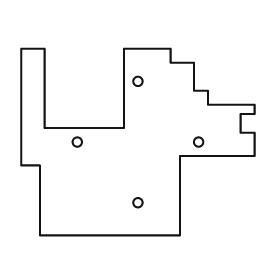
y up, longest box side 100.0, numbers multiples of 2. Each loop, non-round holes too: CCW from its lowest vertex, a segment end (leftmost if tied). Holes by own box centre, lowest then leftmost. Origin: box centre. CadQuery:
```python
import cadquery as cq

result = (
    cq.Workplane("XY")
    .moveTo(-42.0, -40.0)
    .lineTo(18.0, -40.0)
    .lineTo(18.0, -6.0)
    .lineTo(50.0, -6.0)
    .lineTo(50.0, 4.0)
    .lineTo(44.0, 4.0)
    .lineTo(44.0, 12.0)
    .lineTo(50.0, 12.0)
    .lineTo(50.0, 16.0)
    .lineTo(30.0, 16.0)
    .lineTo(30.0, 22.0)
    .lineTo(24.0, 22.0)
    .lineTo(24.0, 34.0)
    .lineTo(14.0, 34.0)
    .lineTo(14.0, 40.0)
    .lineTo(-6.0, 40.0)
    .lineTo(-6.0, 6.0)
    .lineTo(-40.0, 6.0)
    .lineTo(-40.0, 40.0)
    .lineTo(-50.0, 40.0)
    .lineTo(-50.0, -10.0)
    .lineTo(-42.0, -10.0)
    .close()
    .moveTo(0.0, -26.0)
    .circle(2.0)
    .moveTo(-26.0, 0.0)
    .circle(2.0)
    .moveTo(26.0, 0.0)
    .circle(2.0)
    .moveTo(0.0, 26.0)
    .circle(2.0)
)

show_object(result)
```